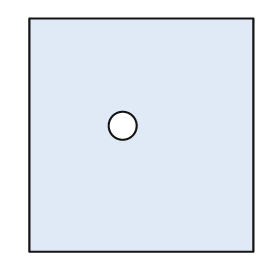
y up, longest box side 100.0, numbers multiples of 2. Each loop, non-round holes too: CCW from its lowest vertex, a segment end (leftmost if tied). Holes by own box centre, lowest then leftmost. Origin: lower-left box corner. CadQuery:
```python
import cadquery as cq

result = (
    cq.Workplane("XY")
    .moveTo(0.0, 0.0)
    .lineTo(96.0, 0.0)
    .lineTo(96.0, 100.0)
    .lineTo(0.0, 100.0)
    .close()
    .moveTo(40.0, 54.0)
    .circle(6.0)
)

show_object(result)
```